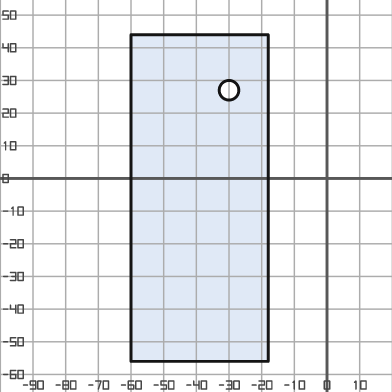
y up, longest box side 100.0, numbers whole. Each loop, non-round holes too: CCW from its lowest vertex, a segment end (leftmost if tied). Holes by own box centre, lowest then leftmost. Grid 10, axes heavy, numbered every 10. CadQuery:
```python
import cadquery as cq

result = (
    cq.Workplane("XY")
    .moveTo(-60.0, -56.0)
    .lineTo(-18.0, -56.0)
    .lineTo(-18.0, 44.0)
    .lineTo(-60.0, 44.0)
    .close()
    .moveTo(-30.0, 27.0)
    .circle(3.0)
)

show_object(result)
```